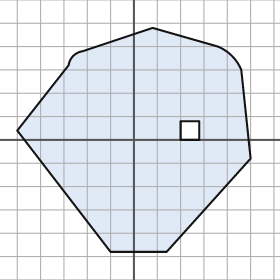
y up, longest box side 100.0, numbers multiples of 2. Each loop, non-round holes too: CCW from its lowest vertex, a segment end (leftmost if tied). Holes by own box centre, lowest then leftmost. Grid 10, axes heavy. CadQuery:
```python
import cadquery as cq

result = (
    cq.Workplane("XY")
    .moveTo(-10.0, -48.0)
    .lineTo(14.0, -48.0)
    .lineTo(50.0, -8.0)
    .lineTo(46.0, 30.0)
    .threePointArc((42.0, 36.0), (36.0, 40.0))
    .lineTo(8.0, 48.0)
    .lineTo(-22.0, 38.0)
    .threePointArc((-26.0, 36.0), (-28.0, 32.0))
    .lineTo(-50.0, 4.0)
    .close()
    .moveTo(20.0, 0.0)
    .lineTo(28.0, 0.0)
    .lineTo(28.0, 8.0)
    .lineTo(20.0, 8.0)
    .close()
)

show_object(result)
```